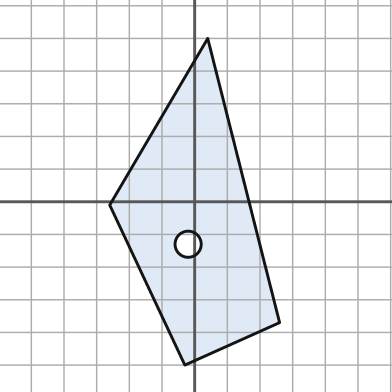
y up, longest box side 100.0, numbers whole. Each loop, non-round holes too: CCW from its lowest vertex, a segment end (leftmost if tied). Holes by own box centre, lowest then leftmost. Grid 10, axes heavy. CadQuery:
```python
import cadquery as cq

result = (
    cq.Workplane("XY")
    .moveTo(-3.0, -50.0)
    .lineTo(26.0, -37.0)
    .lineTo(4.0, 50.0)
    .lineTo(-26.0, -1.0)
    .close()
    .moveTo(-2.0, -13.0)
    .circle(4.0)
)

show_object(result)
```